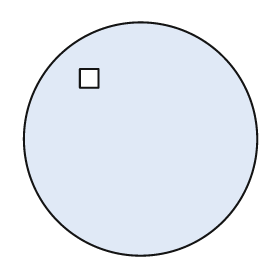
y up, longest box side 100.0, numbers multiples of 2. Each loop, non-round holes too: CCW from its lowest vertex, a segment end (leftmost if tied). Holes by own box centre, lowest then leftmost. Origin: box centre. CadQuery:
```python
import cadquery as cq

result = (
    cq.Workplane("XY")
    .moveTo(0.0, 0.0)
    .circle(50.0)
    .moveTo(-26.0, 22.0)
    .lineTo(-18.0, 22.0)
    .lineTo(-18.0, 30.0)
    .lineTo(-26.0, 30.0)
    .close()
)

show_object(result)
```